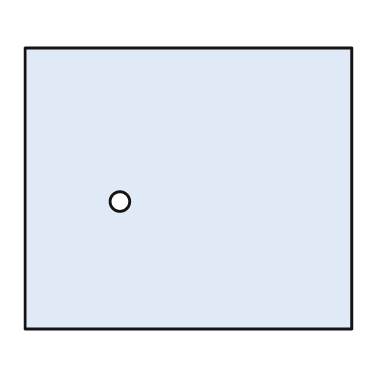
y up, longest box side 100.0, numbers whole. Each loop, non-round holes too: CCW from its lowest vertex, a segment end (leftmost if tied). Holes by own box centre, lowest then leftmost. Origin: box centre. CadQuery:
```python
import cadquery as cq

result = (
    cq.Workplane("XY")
    .moveTo(-50.0, -43.0)
    .lineTo(50.0, -43.0)
    .lineTo(50.0, 43.0)
    .lineTo(-50.0, 43.0)
    .close()
    .moveTo(-21.0, -4.0)
    .circle(3.0)
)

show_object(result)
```